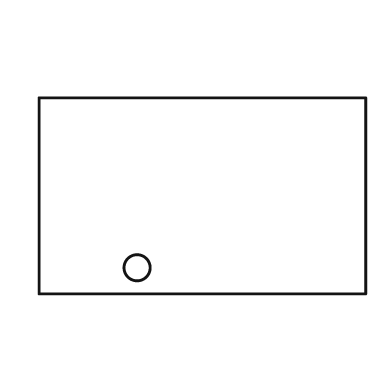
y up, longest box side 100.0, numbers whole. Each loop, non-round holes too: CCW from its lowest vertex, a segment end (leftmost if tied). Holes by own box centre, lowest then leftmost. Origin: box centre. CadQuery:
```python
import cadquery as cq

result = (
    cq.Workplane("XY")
    .moveTo(-50.0, -30.0)
    .lineTo(50.0, -30.0)
    .lineTo(50.0, 30.0)
    .lineTo(-50.0, 30.0)
    .close()
    .moveTo(-20.0, -22.0)
    .circle(4.0)
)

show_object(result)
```